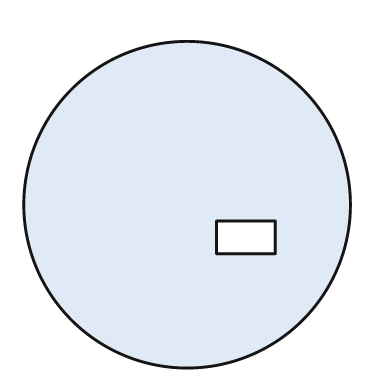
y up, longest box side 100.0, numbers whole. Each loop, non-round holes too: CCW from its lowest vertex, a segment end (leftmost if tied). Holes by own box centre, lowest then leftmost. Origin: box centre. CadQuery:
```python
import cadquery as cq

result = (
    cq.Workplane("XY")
    .moveTo(0.0, 0.0)
    .circle(50.0)
    .moveTo(9.0, -15.0)
    .lineTo(27.0, -15.0)
    .lineTo(27.0, -5.0)
    .lineTo(9.0, -5.0)
    .close()
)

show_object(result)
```